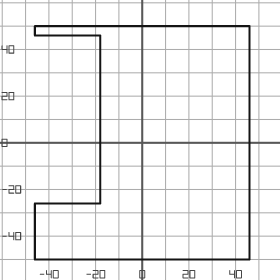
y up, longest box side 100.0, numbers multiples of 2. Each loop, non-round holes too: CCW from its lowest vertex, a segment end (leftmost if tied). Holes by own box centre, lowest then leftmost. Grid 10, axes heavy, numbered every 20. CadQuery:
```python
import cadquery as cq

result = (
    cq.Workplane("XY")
    .moveTo(-46.0, -50.0)
    .lineTo(46.0, -50.0)
    .lineTo(46.0, 50.0)
    .lineTo(-46.0, 50.0)
    .lineTo(-46.0, 46.0)
    .lineTo(-18.0, 46.0)
    .lineTo(-18.0, -26.0)
    .lineTo(-46.0, -26.0)
    .close()
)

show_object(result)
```